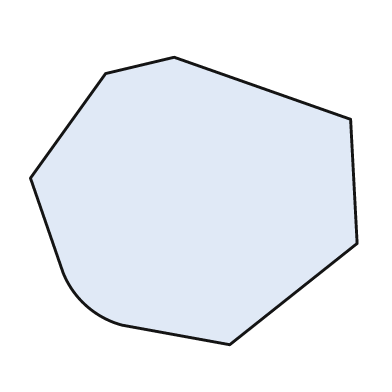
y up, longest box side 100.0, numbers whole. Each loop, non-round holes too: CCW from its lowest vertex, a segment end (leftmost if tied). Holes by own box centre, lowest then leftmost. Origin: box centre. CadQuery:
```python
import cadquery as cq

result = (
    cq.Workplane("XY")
    .moveTo(11.0, -44.0)
    .lineTo(50.0, -13.0)
    .lineTo(48.0, 25.0)
    .lineTo(-6.0, 44.0)
    .lineTo(-27.0, 39.0)
    .lineTo(-50.0, 7.0)
    .lineTo(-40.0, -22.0)
    .threePointArc((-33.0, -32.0), (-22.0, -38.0))
    .close()
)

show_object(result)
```